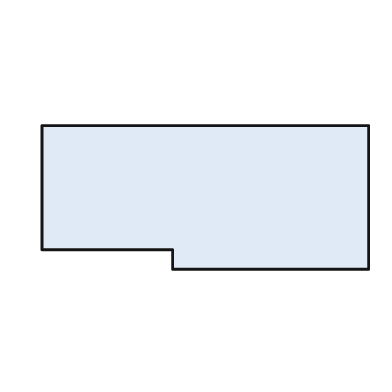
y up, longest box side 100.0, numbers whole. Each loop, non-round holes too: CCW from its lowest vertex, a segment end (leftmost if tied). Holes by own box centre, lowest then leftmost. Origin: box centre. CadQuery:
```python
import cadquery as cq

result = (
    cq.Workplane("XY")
    .moveTo(-10.0, -22.0)
    .lineTo(50.0, -22.0)
    .lineTo(50.0, 22.0)
    .lineTo(-50.0, 22.0)
    .lineTo(-50.0, -16.0)
    .lineTo(-10.0, -16.0)
    .close()
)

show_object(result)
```